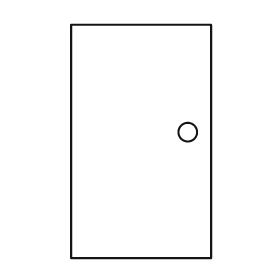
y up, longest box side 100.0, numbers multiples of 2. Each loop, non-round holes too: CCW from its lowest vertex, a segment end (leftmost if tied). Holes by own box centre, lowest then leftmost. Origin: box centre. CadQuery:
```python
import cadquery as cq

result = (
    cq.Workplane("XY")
    .moveTo(-30.0, -50.0)
    .lineTo(30.0, -50.0)
    .lineTo(30.0, 50.0)
    .lineTo(-30.0, 50.0)
    .close()
    .moveTo(20.0, 4.0)
    .circle(4.0)
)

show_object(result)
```